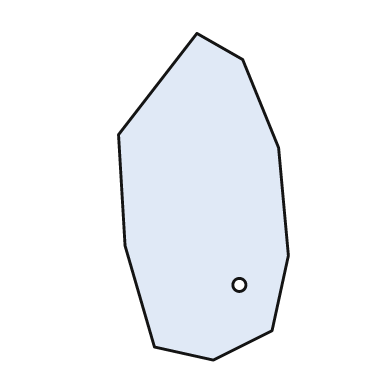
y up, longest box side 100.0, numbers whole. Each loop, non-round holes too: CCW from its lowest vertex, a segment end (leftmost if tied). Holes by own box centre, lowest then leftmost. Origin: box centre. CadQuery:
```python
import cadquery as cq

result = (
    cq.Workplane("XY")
    .moveTo(3.0, -50.0)
    .lineTo(21.0, -41.0)
    .lineTo(26.0, -18.0)
    .lineTo(23.0, 15.0)
    .lineTo(12.0, 42.0)
    .lineTo(-2.0, 50.0)
    .lineTo(-26.0, 19.0)
    .lineTo(-24.0, -15.0)
    .lineTo(-15.0, -46.0)
    .close()
    .moveTo(11.0, -27.0)
    .circle(2.0)
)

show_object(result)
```